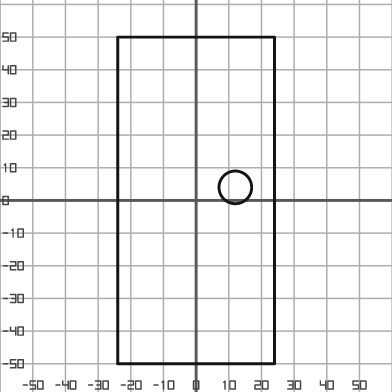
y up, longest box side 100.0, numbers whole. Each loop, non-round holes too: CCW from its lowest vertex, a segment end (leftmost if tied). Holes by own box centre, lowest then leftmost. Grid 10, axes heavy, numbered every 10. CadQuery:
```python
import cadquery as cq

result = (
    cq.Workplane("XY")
    .moveTo(-24.0, -50.0)
    .lineTo(24.0, -50.0)
    .lineTo(24.0, 50.0)
    .lineTo(-24.0, 50.0)
    .close()
    .moveTo(12.0, 4.0)
    .circle(5.0)
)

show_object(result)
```